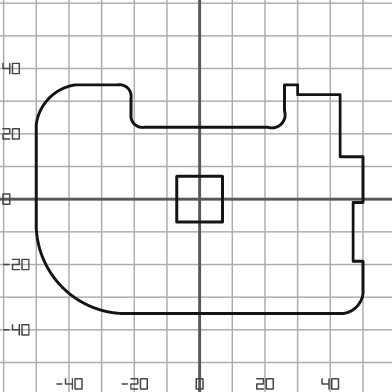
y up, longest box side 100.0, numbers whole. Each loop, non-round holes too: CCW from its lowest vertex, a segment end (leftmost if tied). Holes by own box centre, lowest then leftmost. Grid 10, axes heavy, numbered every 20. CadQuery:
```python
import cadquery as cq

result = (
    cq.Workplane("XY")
    .moveTo(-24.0, -35.0)
    .lineTo(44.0, -35.0)
    .threePointArc((48.0, -33.0), (50.0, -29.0))
    .lineTo(50.0, -19.0)
    .lineTo(47.0, -19.0)
    .lineTo(47.0, -1.0)
    .lineTo(50.0, -1.0)
    .lineTo(50.0, 13.0)
    .lineTo(43.0, 13.0)
    .lineTo(43.0, 32.0)
    .lineTo(30.0, 32.0)
    .lineTo(30.0, 35.0)
    .lineTo(26.0, 35.0)
    .lineTo(26.0, 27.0)
    .threePointArc((25.0, 23.0), (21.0, 22.0))
    .lineTo(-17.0, 22.0)
    .threePointArc((-20.0, 23.0), (-21.0, 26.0))
    .lineTo(-21.0, 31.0)
    .threePointArc((-22.0, 34.0), (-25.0, 35.0))
    .lineTo(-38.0, 35.0)
    .threePointArc((-46.0, 31.0), (-50.0, 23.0))
    .lineTo(-50.0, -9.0)
    .threePointArc((-42.0, -27.0), (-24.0, -35.0))
    .close()
    .moveTo(-7.0, -7.0)
    .lineTo(7.0, -7.0)
    .lineTo(7.0, 7.0)
    .lineTo(-7.0, 7.0)
    .close()
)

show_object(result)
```